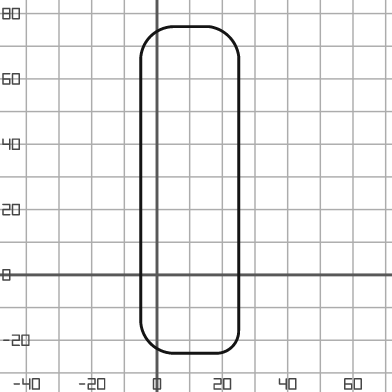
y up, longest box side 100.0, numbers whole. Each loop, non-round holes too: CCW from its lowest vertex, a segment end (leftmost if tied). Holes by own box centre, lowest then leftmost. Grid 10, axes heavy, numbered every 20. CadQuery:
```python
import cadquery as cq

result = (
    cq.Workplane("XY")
    .moveTo(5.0, -24.0)
    .lineTo(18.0, -24.0)
    .threePointArc((23.0, -22.0), (25.0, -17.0))
    .lineTo(25.0, 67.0)
    .threePointArc((22.0, 73.0), (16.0, 76.0))
    .lineTo(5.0, 76.0)
    .threePointArc((-2.0, 73.0), (-5.0, 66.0))
    .lineTo(-5.0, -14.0)
    .threePointArc((-2.0, -21.0), (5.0, -24.0))
    .close()
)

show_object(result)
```